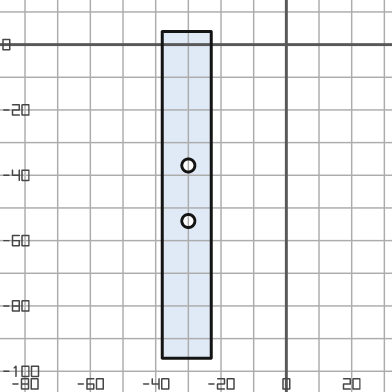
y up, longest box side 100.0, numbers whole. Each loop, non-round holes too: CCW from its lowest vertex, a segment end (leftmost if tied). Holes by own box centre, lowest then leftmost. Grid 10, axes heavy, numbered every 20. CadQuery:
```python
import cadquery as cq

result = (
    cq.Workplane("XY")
    .moveTo(-38.0, -96.0)
    .lineTo(-23.0, -96.0)
    .lineTo(-23.0, 4.0)
    .lineTo(-38.0, 4.0)
    .close()
    .moveTo(-30.0, -54.0)
    .circle(2.0)
    .moveTo(-30.0, -37.0)
    .circle(2.0)
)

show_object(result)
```